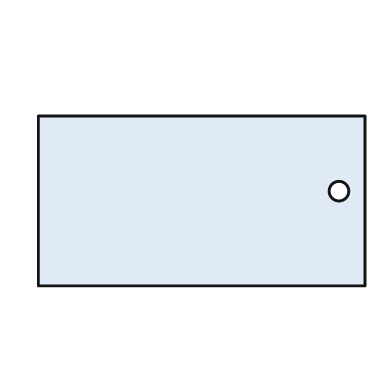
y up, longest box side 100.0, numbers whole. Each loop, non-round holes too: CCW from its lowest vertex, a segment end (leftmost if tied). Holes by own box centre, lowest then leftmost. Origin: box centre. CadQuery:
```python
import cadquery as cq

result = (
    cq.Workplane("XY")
    .moveTo(-50.0, -26.0)
    .lineTo(50.0, -26.0)
    .lineTo(50.0, 26.0)
    .lineTo(-50.0, 26.0)
    .close()
    .moveTo(42.0, 3.0)
    .circle(3.0)
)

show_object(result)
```